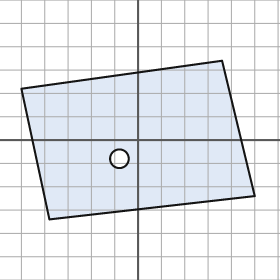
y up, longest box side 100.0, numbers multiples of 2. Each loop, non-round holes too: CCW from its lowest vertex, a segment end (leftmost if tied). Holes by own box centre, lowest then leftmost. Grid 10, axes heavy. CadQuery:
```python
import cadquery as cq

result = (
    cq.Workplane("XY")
    .moveTo(-38.0, -34.0)
    .lineTo(50.0, -24.0)
    .lineTo(36.0, 34.0)
    .lineTo(-50.0, 22.0)
    .close()
    .moveTo(-8.0, -8.0)
    .circle(4.0)
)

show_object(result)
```